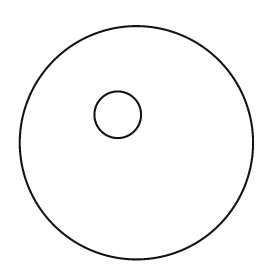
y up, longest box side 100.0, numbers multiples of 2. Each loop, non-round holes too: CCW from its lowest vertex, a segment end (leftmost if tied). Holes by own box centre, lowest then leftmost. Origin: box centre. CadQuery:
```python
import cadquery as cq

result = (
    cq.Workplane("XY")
    .moveTo(0.0, 0.0)
    .circle(50.0)
    .moveTo(-8.0, 12.0)
    .circle(10.0)
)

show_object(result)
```